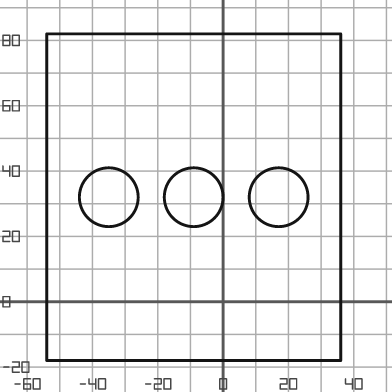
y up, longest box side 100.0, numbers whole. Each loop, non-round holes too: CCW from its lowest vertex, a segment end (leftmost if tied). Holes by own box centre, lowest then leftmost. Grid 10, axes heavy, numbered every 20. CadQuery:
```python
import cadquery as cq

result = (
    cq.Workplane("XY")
    .moveTo(-54.0, -18.0)
    .lineTo(36.0, -18.0)
    .lineTo(36.0, 82.0)
    .lineTo(-54.0, 82.0)
    .close()
    .moveTo(-35.0, 32.0)
    .circle(9.0)
    .moveTo(-9.0, 32.0)
    .circle(9.0)
    .moveTo(17.0, 32.0)
    .circle(9.0)
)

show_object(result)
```